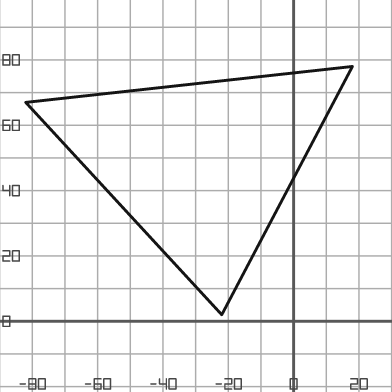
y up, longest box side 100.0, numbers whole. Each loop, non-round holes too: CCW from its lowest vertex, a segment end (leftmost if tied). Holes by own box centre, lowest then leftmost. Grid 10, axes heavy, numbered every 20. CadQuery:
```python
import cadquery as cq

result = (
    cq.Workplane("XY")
    .moveTo(-22.0, 2.0)
    .lineTo(18.0, 78.0)
    .lineTo(-82.0, 67.0)
    .close()
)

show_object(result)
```